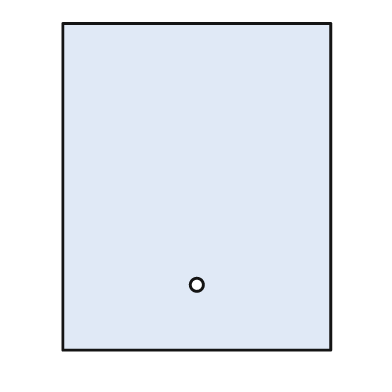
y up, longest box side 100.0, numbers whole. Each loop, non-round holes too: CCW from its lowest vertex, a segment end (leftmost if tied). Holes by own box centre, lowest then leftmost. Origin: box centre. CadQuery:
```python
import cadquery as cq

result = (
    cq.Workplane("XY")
    .moveTo(-41.0, -50.0)
    .lineTo(41.0, -50.0)
    .lineTo(41.0, 50.0)
    .lineTo(-41.0, 50.0)
    .close()
    .moveTo(0.0, -30.0)
    .circle(2.0)
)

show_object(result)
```